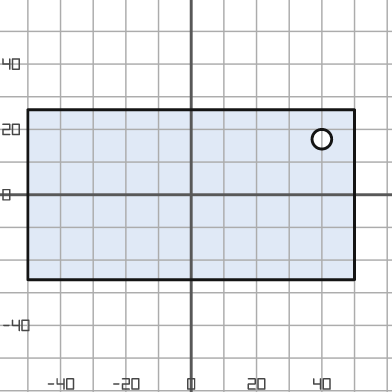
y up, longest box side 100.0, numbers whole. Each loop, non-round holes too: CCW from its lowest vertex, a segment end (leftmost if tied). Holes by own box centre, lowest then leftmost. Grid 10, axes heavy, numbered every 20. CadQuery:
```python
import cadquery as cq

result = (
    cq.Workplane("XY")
    .moveTo(-50.0, -26.0)
    .lineTo(50.0, -26.0)
    .lineTo(50.0, 26.0)
    .lineTo(-50.0, 26.0)
    .close()
    .moveTo(40.0, 17.0)
    .circle(3.0)
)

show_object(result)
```